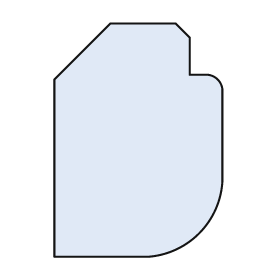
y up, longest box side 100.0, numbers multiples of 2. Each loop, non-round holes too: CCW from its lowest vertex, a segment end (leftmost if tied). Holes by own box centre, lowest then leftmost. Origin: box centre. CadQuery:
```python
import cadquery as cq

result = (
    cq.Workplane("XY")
    .moveTo(-36.0, -50.0)
    .lineTo(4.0, -50.0)
    .threePointArc((26.0, -40.0), (36.0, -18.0))
    .lineTo(36.0, 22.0)
    .threePointArc((34.0, 26.0), (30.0, 28.0))
    .lineTo(22.0, 28.0)
    .lineTo(22.0, 44.0)
    .lineTo(16.0, 50.0)
    .lineTo(-12.0, 50.0)
    .lineTo(-36.0, 26.0)
    .close()
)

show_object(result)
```